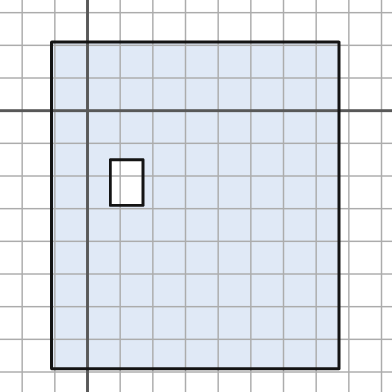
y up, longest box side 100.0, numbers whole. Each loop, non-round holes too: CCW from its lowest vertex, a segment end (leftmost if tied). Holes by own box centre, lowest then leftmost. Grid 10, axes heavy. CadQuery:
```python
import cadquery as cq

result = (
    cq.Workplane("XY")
    .moveTo(-11.0, -79.0)
    .lineTo(77.0, -79.0)
    .lineTo(77.0, 21.0)
    .lineTo(-11.0, 21.0)
    .close()
    .moveTo(7.0, -29.0)
    .lineTo(17.0, -29.0)
    .lineTo(17.0, -15.0)
    .lineTo(7.0, -15.0)
    .close()
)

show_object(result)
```